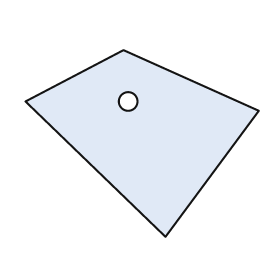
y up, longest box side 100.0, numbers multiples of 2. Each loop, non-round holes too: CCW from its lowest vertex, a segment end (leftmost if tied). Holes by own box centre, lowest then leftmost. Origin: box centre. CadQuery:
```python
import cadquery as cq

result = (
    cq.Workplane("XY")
    .moveTo(10.0, -40.0)
    .lineTo(50.0, 14.0)
    .lineTo(-8.0, 40.0)
    .lineTo(-50.0, 18.0)
    .close()
    .moveTo(-6.0, 18.0)
    .circle(4.0)
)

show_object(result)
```